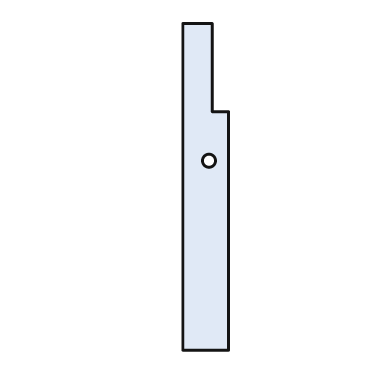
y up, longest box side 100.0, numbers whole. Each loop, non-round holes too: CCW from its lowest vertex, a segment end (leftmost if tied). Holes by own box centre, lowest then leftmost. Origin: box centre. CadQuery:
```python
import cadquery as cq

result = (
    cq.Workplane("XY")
    .moveTo(-7.0, -50.0)
    .lineTo(7.0, -50.0)
    .lineTo(7.0, 23.0)
    .lineTo(2.0, 23.0)
    .lineTo(2.0, 50.0)
    .lineTo(-7.0, 50.0)
    .close()
    .moveTo(1.0, 8.0)
    .circle(2.0)
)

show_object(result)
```